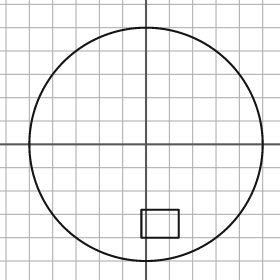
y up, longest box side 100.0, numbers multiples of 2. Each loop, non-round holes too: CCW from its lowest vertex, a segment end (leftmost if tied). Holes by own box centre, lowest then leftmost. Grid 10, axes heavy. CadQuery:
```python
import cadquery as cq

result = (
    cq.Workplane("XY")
    .moveTo(0.0, 0.0)
    .circle(50.0)
    .moveTo(-2.0, -40.0)
    .lineTo(14.0, -40.0)
    .lineTo(14.0, -28.0)
    .lineTo(-2.0, -28.0)
    .close()
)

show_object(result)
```